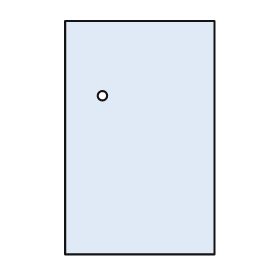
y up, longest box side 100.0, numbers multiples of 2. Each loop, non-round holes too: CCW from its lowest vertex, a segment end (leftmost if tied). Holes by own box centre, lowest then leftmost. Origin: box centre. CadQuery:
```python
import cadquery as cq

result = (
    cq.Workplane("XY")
    .moveTo(-32.0, -50.0)
    .lineTo(32.0, -50.0)
    .lineTo(32.0, 50.0)
    .lineTo(-32.0, 50.0)
    .close()
    .moveTo(-16.0, 18.0)
    .circle(2.0)
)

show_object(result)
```